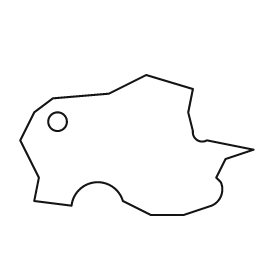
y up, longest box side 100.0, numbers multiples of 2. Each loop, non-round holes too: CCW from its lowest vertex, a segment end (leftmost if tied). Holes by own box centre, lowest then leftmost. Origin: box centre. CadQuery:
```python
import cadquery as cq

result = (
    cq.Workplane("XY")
    .moveTo(6.0, -30.0)
    .lineTo(20.0, -30.0)
    .lineTo(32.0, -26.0)
    .threePointArc((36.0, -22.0), (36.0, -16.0))
    .lineTo(34.0, -14.0)
    .lineTo(38.0, -6.0)
    .lineTo(50.0, -2.0)
    .lineTo(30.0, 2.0)
    .threePointArc((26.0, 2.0), (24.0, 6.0))
    .lineTo(22.0, 14.0)
    .lineTo(24.0, 24.0)
    .lineTo(4.0, 30.0)
    .lineTo(-12.0, 22.0)
    .lineTo(-36.0, 20.0)
    .lineTo(-44.0, 14.0)
    .lineTo(-50.0, 2.0)
    .lineTo(-42.0, -14.0)
    .lineTo(-44.0, -24.0)
    .lineTo(-28.0, -26.0)
    .threePointArc((-18.0, -16.0), (-6.0, -24.0))
    .close()
    .moveTo(-34.0, 10.0)
    .circle(4.0)
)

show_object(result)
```